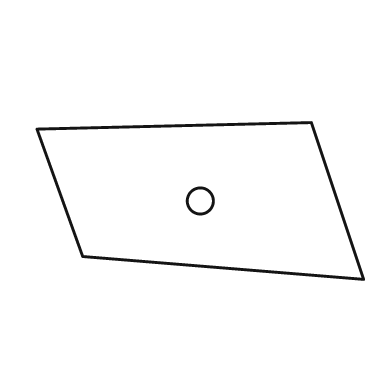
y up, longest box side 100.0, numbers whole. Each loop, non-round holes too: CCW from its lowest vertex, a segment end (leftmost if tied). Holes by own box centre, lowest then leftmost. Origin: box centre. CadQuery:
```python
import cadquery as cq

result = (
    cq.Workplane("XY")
    .moveTo(50.0, -24.0)
    .lineTo(34.0, 24.0)
    .lineTo(-50.0, 22.0)
    .lineTo(-36.0, -17.0)
    .close()
    .moveTo(0.0, 0.0)
    .circle(4.0)
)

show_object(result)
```